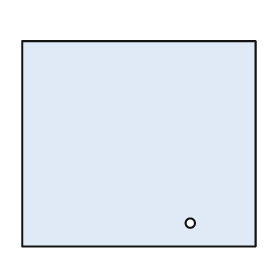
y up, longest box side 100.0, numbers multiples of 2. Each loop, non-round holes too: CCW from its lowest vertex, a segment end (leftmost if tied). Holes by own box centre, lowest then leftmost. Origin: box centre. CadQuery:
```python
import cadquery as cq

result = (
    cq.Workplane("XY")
    .moveTo(-50.0, -44.0)
    .lineTo(50.0, -44.0)
    .lineTo(50.0, 44.0)
    .lineTo(-50.0, 44.0)
    .close()
    .moveTo(22.0, -34.0)
    .circle(2.0)
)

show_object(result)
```